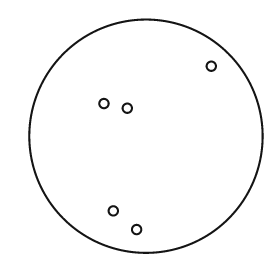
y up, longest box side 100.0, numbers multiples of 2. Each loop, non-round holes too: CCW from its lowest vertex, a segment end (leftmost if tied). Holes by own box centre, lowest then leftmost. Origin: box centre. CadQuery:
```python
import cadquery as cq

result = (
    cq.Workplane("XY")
    .moveTo(0.0, 0.0)
    .circle(50.0)
    .moveTo(-4.0, -40.0)
    .circle(2.0)
    .moveTo(-14.0, -32.0)
    .circle(2.0)
    .moveTo(-8.0, 12.0)
    .circle(2.0)
    .moveTo(-18.0, 14.0)
    .circle(2.0)
    .moveTo(28.0, 30.0)
    .circle(2.0)
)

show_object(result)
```